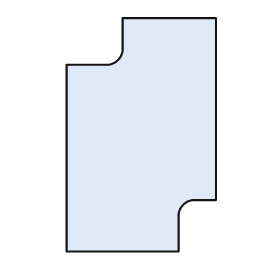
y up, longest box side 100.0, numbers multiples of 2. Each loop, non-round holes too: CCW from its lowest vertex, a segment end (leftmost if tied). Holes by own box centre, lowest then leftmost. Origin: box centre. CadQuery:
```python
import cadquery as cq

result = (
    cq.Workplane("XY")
    .moveTo(-32.0, -50.0)
    .lineTo(16.0, -50.0)
    .lineTo(16.0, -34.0)
    .threePointArc((18.0, -30.0), (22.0, -28.0))
    .lineTo(32.0, -28.0)
    .lineTo(32.0, 50.0)
    .lineTo(-8.0, 50.0)
    .lineTo(-8.0, 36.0)
    .threePointArc((-10.0, 32.0), (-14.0, 30.0))
    .lineTo(-32.0, 30.0)
    .close()
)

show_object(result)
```